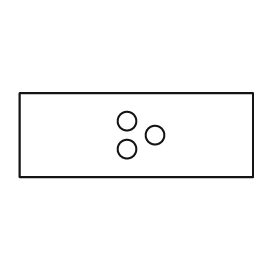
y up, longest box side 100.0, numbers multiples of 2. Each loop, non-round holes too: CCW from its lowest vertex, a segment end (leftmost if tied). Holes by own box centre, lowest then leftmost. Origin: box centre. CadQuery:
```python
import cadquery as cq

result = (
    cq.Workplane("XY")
    .moveTo(-50.0, -18.0)
    .lineTo(50.0, -18.0)
    .lineTo(50.0, 18.0)
    .lineTo(-50.0, 18.0)
    .close()
    .moveTo(-4.0, -6.0)
    .circle(4.0)
    .moveTo(8.0, 0.0)
    .circle(4.0)
    .moveTo(-4.0, 6.0)
    .circle(4.0)
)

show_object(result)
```